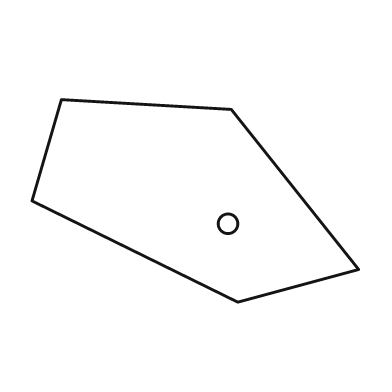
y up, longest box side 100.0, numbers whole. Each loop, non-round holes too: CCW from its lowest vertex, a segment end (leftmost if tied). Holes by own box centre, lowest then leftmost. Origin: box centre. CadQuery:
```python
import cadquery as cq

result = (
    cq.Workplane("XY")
    .moveTo(13.0, -31.0)
    .lineTo(50.0, -21.0)
    .lineTo(11.0, 28.0)
    .lineTo(-41.0, 31.0)
    .lineTo(-50.0, 0.0)
    .close()
    .moveTo(10.0, -7.0)
    .circle(3.0)
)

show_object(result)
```